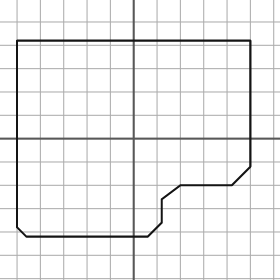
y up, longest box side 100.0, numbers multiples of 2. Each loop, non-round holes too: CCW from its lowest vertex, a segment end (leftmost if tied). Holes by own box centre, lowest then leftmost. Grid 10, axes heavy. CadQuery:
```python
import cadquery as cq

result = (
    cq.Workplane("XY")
    .moveTo(-46.0, -42.0)
    .lineTo(6.0, -42.0)
    .lineTo(12.0, -36.0)
    .lineTo(12.0, -26.0)
    .lineTo(20.0, -20.0)
    .lineTo(42.0, -20.0)
    .lineTo(50.0, -12.0)
    .lineTo(50.0, 42.0)
    .lineTo(-50.0, 42.0)
    .lineTo(-50.0, -38.0)
    .close()
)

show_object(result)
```